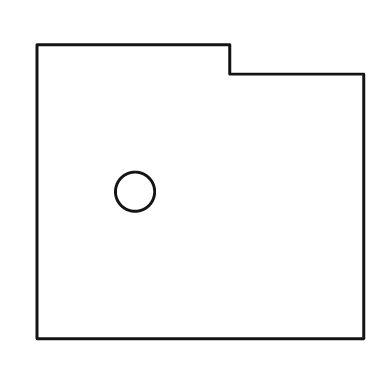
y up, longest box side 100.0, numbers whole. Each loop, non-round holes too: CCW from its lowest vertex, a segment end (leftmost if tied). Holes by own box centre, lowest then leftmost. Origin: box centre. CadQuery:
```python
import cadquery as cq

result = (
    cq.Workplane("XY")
    .moveTo(-50.0, -45.0)
    .lineTo(50.0, -45.0)
    .lineTo(50.0, 36.0)
    .lineTo(9.0, 36.0)
    .lineTo(9.0, 45.0)
    .lineTo(-50.0, 45.0)
    .close()
    .moveTo(-20.0, 0.0)
    .circle(6.0)
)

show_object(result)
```